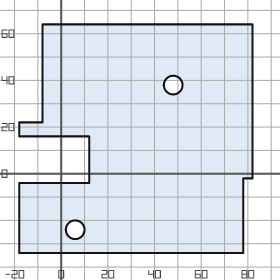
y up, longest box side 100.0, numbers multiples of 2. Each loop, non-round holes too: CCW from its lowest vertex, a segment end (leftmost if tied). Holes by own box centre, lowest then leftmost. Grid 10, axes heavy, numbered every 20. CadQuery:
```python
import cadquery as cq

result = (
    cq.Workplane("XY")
    .moveTo(-18.0, -34.0)
    .lineTo(78.0, -34.0)
    .lineTo(78.0, -2.0)
    .lineTo(82.0, -2.0)
    .lineTo(82.0, 64.0)
    .lineTo(-8.0, 64.0)
    .lineTo(-8.0, 22.0)
    .lineTo(-18.0, 22.0)
    .lineTo(-18.0, 16.0)
    .lineTo(12.0, 16.0)
    .lineTo(12.0, -4.0)
    .lineTo(-18.0, -4.0)
    .close()
    .moveTo(6.0, -24.0)
    .circle(4.0)
    .moveTo(48.0, 38.0)
    .circle(4.0)
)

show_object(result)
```